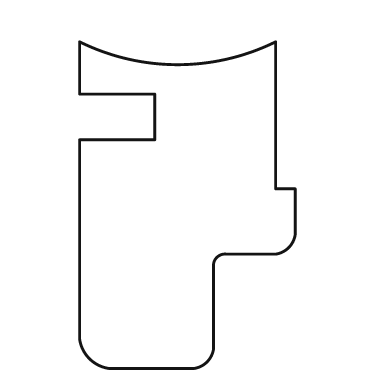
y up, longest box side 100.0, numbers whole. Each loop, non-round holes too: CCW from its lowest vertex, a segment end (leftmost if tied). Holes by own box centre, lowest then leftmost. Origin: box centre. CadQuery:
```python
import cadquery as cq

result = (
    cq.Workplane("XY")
    .moveTo(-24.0, -50.0)
    .lineTo(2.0, -50.0)
    .threePointArc((6.0, -48.0), (8.0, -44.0))
    .lineTo(8.0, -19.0)
    .threePointArc((9.0, -16.0), (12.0, -15.0))
    .lineTo(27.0, -15.0)
    .threePointArc((31.0, -13.0), (33.0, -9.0))
    .lineTo(33.0, 5.0)
    .lineTo(27.0, 5.0)
    .lineTo(27.0, 50.0)
    .threePointArc((-3.0, 43.0), (-33.0, 50.0))
    .lineTo(-33.0, 34.0)
    .lineTo(-10.0, 34.0)
    .lineTo(-10.0, 20.0)
    .lineTo(-33.0, 20.0)
    .lineTo(-33.0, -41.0)
    .threePointArc((-30.0, -47.0), (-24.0, -50.0))
    .close()
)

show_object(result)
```